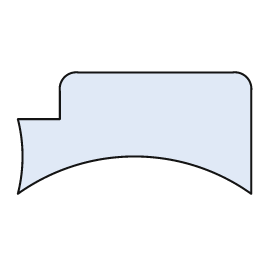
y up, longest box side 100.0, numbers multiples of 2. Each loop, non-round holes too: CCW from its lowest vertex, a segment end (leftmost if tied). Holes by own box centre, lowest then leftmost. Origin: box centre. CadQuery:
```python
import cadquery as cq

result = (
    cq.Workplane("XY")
    .moveTo(-50.0, -26.0)
    .threePointArc((0.0, -10.0), (50.0, -26.0))
    .lineTo(50.0, 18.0)
    .threePointArc((48.0, 24.0), (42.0, 26.0))
    .lineTo(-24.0, 26.0)
    .threePointArc((-30.0, 24.0), (-32.0, 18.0))
    .lineTo(-32.0, 6.0)
    .lineTo(-50.0, 6.0)
    .threePointArc((-48.0, -10.0), (-50.0, -26.0))
    .close()
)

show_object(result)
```